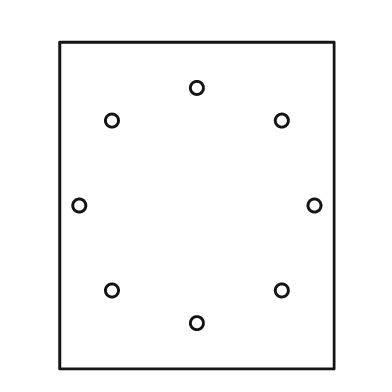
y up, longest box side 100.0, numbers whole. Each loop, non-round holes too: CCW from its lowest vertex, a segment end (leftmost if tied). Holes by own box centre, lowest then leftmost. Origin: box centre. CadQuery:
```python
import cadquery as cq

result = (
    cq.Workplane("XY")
    .moveTo(-42.0, -50.0)
    .lineTo(42.0, -50.0)
    .lineTo(42.0, 50.0)
    .lineTo(-42.0, 50.0)
    .close()
    .moveTo(0.0, -36.0)
    .circle(2.0)
    .moveTo(-26.0, -26.0)
    .circle(2.0)
    .moveTo(26.0, -26.0)
    .circle(2.0)
    .moveTo(-36.0, 0.0)
    .circle(2.0)
    .moveTo(36.0, 0.0)
    .circle(2.0)
    .moveTo(-26.0, 26.0)
    .circle(2.0)
    .moveTo(26.0, 26.0)
    .circle(2.0)
    .moveTo(0.0, 36.0)
    .circle(2.0)
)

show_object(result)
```